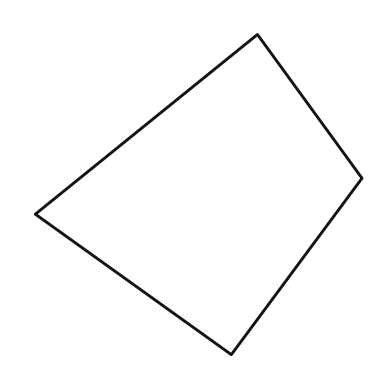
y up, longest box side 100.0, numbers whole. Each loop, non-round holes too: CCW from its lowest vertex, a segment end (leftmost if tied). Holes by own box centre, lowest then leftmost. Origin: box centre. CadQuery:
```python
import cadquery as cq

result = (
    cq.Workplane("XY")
    .moveTo(10.0, -49.0)
    .lineTo(50.0, 5.0)
    .lineTo(18.0, 49.0)
    .lineTo(-50.0, -6.0)
    .close()
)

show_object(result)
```